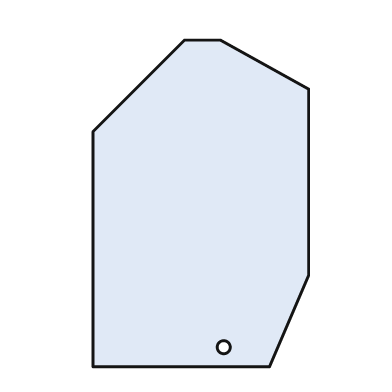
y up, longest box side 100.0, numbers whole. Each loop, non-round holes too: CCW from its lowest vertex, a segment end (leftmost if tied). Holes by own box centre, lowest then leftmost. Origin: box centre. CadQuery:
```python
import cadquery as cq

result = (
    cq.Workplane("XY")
    .moveTo(-33.0, -50.0)
    .lineTo(21.0, -50.0)
    .lineTo(33.0, -22.0)
    .lineTo(33.0, 35.0)
    .lineTo(6.0, 50.0)
    .lineTo(-5.0, 50.0)
    .lineTo(-33.0, 22.0)
    .close()
    .moveTo(7.0, -44.0)
    .circle(2.0)
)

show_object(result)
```